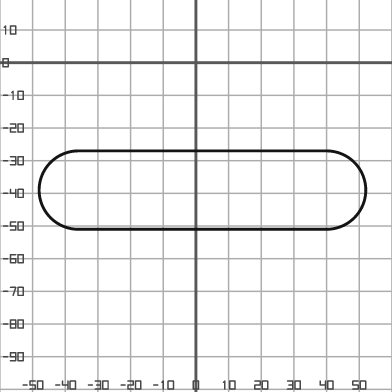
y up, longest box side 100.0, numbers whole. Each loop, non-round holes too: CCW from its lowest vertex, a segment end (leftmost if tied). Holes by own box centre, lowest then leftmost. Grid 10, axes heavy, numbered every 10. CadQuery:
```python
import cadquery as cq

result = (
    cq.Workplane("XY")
    .moveTo(-36.0, -51.0)
    .lineTo(40.0, -51.0)
    .threePointArc((52.0, -39.0), (40.0, -27.0))
    .lineTo(-36.0, -27.0)
    .threePointArc((-48.0, -39.0), (-36.0, -51.0))
    .close()
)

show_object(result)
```